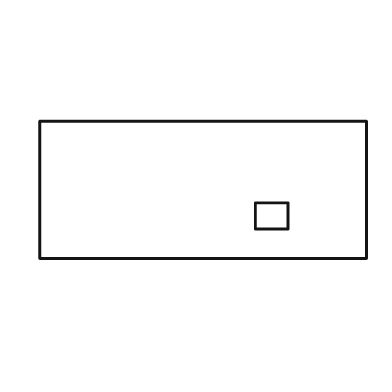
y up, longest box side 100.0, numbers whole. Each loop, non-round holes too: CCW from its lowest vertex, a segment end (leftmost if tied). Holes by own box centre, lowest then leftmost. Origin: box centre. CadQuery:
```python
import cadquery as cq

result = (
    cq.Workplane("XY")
    .moveTo(-50.0, -21.0)
    .lineTo(50.0, -21.0)
    .lineTo(50.0, 21.0)
    .lineTo(-50.0, 21.0)
    .close()
    .moveTo(16.0, -12.0)
    .lineTo(26.0, -12.0)
    .lineTo(26.0, -4.0)
    .lineTo(16.0, -4.0)
    .close()
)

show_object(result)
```